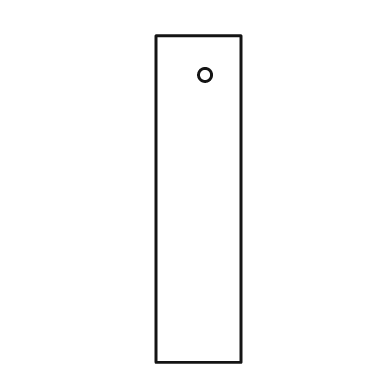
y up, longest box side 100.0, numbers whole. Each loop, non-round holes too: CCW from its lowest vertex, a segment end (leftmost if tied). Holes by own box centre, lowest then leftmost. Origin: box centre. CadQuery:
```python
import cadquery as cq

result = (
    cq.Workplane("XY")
    .moveTo(-13.0, -50.0)
    .lineTo(13.0, -50.0)
    .lineTo(13.0, 50.0)
    .lineTo(-13.0, 50.0)
    .close()
    .moveTo(2.0, 38.0)
    .circle(2.0)
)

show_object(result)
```